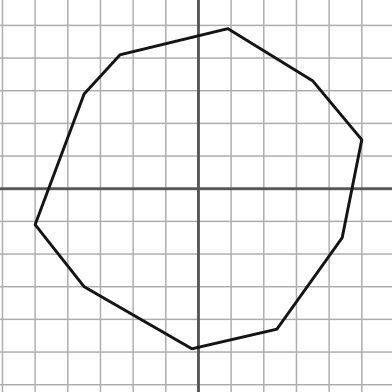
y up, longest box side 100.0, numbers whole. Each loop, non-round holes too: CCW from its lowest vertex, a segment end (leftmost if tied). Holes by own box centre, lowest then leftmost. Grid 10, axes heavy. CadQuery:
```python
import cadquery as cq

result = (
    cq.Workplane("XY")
    .moveTo(-2.0, -49.0)
    .lineTo(24.0, -43.0)
    .lineTo(44.0, -15.0)
    .lineTo(50.0, 15.0)
    .lineTo(35.0, 33.0)
    .lineTo(9.0, 49.0)
    .lineTo(-24.0, 41.0)
    .lineTo(-35.0, 29.0)
    .lineTo(-50.0, -11.0)
    .lineTo(-35.0, -30.0)
    .close()
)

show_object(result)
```